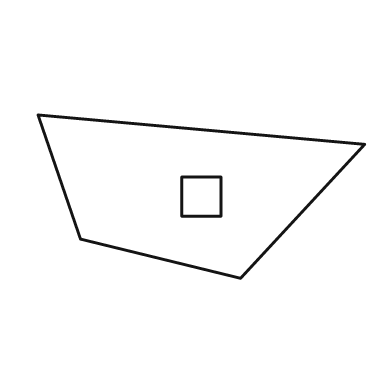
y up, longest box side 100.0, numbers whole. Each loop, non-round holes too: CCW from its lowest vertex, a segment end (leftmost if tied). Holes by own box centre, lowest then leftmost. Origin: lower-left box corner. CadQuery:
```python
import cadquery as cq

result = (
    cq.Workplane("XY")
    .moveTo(62.0, 0.0)
    .lineTo(100.0, 41.0)
    .lineTo(0.0, 50.0)
    .lineTo(13.0, 12.0)
    .close()
    .moveTo(44.0, 19.0)
    .lineTo(56.0, 19.0)
    .lineTo(56.0, 31.0)
    .lineTo(44.0, 31.0)
    .close()
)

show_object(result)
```